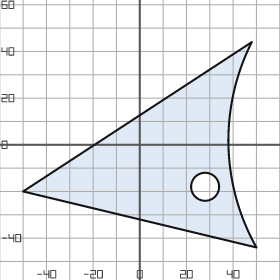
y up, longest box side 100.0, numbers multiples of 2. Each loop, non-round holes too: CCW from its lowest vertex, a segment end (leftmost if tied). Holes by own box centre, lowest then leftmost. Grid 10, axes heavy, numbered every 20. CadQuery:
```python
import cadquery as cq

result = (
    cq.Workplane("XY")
    .moveTo(50.0, -44.0)
    .threePointArc((38.0, 0.0), (48.0, 44.0))
    .lineTo(-50.0, -20.0)
    .close()
    .moveTo(28.0, -18.0)
    .circle(6.0)
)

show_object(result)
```